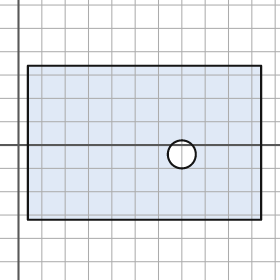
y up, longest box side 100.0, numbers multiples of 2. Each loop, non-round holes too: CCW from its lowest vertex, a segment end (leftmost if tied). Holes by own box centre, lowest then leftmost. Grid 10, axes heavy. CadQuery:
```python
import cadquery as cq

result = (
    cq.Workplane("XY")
    .moveTo(4.0, -32.0)
    .lineTo(104.0, -32.0)
    .lineTo(104.0, 34.0)
    .lineTo(4.0, 34.0)
    .close()
    .moveTo(70.0, -4.0)
    .circle(6.0)
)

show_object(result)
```